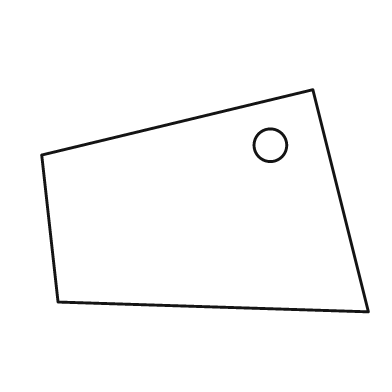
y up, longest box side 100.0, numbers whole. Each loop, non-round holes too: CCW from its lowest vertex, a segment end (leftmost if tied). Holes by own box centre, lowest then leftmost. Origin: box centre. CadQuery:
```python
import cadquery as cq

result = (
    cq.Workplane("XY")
    .moveTo(50.0, -34.0)
    .lineTo(33.0, 34.0)
    .lineTo(-50.0, 14.0)
    .lineTo(-45.0, -31.0)
    .close()
    .moveTo(20.0, 17.0)
    .circle(5.0)
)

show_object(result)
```